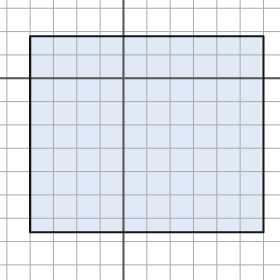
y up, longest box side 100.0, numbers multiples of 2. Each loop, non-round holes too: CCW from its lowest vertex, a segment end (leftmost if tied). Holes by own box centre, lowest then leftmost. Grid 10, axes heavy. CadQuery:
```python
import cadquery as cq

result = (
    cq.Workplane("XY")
    .moveTo(-40.0, -66.0)
    .lineTo(60.0, -66.0)
    .lineTo(60.0, 18.0)
    .lineTo(-40.0, 18.0)
    .close()
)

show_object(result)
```